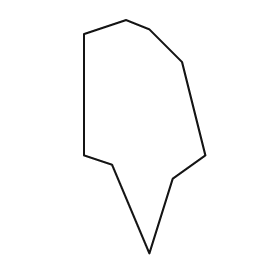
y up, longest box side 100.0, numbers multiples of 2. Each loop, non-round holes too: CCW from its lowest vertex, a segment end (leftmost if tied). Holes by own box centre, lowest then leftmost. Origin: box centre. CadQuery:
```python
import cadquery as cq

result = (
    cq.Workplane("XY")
    .moveTo(2.0, -50.0)
    .lineTo(12.0, -18.0)
    .lineTo(26.0, -8.0)
    .lineTo(16.0, 32.0)
    .lineTo(2.0, 46.0)
    .lineTo(-8.0, 50.0)
    .lineTo(-26.0, 44.0)
    .lineTo(-26.0, -8.0)
    .lineTo(-14.0, -12.0)
    .close()
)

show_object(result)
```